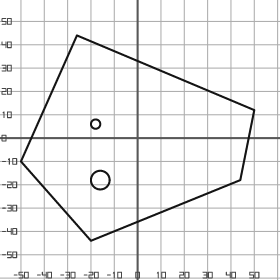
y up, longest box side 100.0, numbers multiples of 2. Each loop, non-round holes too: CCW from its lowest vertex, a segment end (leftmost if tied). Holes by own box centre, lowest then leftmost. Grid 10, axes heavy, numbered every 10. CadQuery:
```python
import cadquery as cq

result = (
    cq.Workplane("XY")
    .moveTo(-20.0, -44.0)
    .lineTo(44.0, -18.0)
    .lineTo(50.0, 12.0)
    .lineTo(-26.0, 44.0)
    .lineTo(-50.0, -10.0)
    .close()
    .moveTo(-16.0, -18.0)
    .circle(4.0)
    .moveTo(-18.0, 6.0)
    .circle(2.0)
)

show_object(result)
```